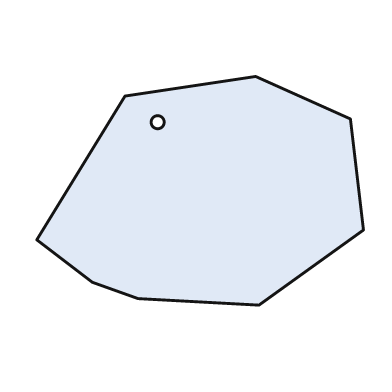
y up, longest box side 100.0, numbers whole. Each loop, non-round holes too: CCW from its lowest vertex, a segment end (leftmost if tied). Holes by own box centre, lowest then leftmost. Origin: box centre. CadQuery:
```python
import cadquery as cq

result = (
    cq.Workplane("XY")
    .moveTo(18.0, -35.0)
    .lineTo(50.0, -12.0)
    .lineTo(46.0, 22.0)
    .lineTo(17.0, 35.0)
    .lineTo(-23.0, 29.0)
    .lineTo(-50.0, -15.0)
    .lineTo(-33.0, -28.0)
    .lineTo(-19.0, -33.0)
    .close()
    .moveTo(-13.0, 21.0)
    .circle(2.0)
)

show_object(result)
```